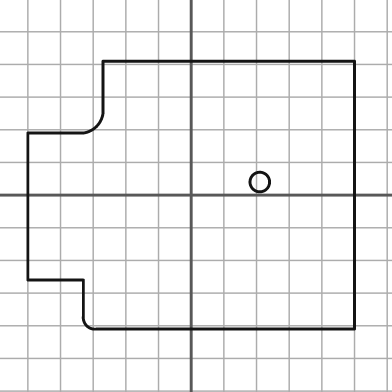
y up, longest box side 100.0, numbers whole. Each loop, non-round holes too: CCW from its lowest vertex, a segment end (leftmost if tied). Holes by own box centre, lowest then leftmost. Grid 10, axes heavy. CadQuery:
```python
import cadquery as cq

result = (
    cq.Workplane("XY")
    .moveTo(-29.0, -41.0)
    .lineTo(50.0, -41.0)
    .lineTo(50.0, 41.0)
    .lineTo(-27.0, 41.0)
    .lineTo(-27.0, 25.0)
    .threePointArc((-29.0, 21.0), (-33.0, 19.0))
    .lineTo(-50.0, 19.0)
    .lineTo(-50.0, -26.0)
    .lineTo(-33.0, -26.0)
    .lineTo(-33.0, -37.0)
    .threePointArc((-32.0, -40.0), (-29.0, -41.0))
    .close()
    .moveTo(21.0, 4.0)
    .circle(3.0)
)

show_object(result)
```